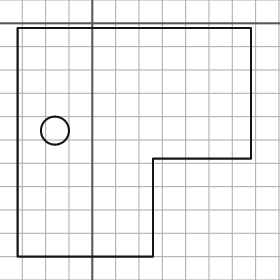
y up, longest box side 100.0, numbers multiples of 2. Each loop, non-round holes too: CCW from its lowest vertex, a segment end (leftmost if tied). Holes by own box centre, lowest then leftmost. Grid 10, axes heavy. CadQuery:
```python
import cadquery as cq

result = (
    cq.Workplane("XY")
    .moveTo(-32.0, -100.0)
    .lineTo(26.0, -100.0)
    .lineTo(26.0, -58.0)
    .lineTo(68.0, -58.0)
    .lineTo(68.0, -2.0)
    .lineTo(-32.0, -2.0)
    .close()
    .moveTo(-16.0, -46.0)
    .circle(6.0)
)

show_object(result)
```